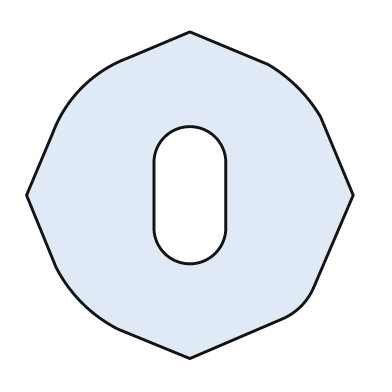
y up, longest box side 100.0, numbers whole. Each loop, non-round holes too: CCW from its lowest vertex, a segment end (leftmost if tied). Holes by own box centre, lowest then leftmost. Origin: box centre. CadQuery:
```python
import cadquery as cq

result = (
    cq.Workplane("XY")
    .moveTo(0.0, -50.0)
    .lineTo(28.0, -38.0)
    .threePointArc((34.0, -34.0), (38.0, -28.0))
    .lineTo(50.0, 0.0)
    .lineTo(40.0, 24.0)
    .threePointArc((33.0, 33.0), (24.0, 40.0))
    .lineTo(0.0, 50.0)
    .lineTo(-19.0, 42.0)
    .threePointArc((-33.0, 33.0), (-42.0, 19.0))
    .lineTo(-50.0, 0.0)
    .lineTo(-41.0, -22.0)
    .threePointArc((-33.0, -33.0), (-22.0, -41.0))
    .close()
    .moveTo(-11.0, -10.0)
    .threePointArc((0.0, -21.0), (11.0, -10.0))
    .lineTo(11.0, 10.0)
    .threePointArc((0.0, 21.0), (-11.0, 10.0))
    .close()
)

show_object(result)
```